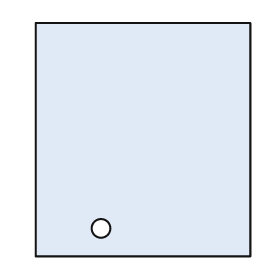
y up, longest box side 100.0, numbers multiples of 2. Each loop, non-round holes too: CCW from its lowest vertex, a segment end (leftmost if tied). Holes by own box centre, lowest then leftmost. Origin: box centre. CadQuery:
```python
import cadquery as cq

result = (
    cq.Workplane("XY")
    .moveTo(-46.0, -50.0)
    .lineTo(46.0, -50.0)
    .lineTo(46.0, 50.0)
    .lineTo(-46.0, 50.0)
    .close()
    .moveTo(-18.0, -38.0)
    .circle(4.0)
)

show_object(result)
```